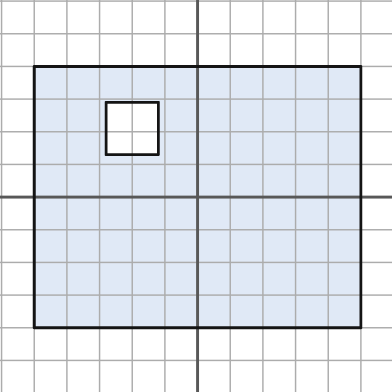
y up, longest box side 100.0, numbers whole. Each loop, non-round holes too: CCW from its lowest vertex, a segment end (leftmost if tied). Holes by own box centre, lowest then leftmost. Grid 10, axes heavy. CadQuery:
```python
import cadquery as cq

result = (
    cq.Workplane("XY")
    .moveTo(-50.0, -40.0)
    .lineTo(50.0, -40.0)
    .lineTo(50.0, 40.0)
    .lineTo(-50.0, 40.0)
    .close()
    .moveTo(-28.0, 13.0)
    .lineTo(-12.0, 13.0)
    .lineTo(-12.0, 29.0)
    .lineTo(-28.0, 29.0)
    .close()
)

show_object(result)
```